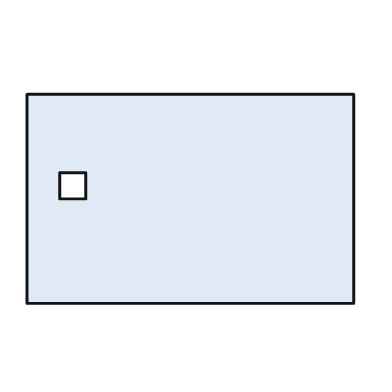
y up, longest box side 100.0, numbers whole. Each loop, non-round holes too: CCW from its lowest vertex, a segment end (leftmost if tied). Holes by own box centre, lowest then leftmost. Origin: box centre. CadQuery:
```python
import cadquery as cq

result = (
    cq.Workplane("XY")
    .moveTo(-50.0, -32.0)
    .lineTo(50.0, -32.0)
    .lineTo(50.0, 32.0)
    .lineTo(-50.0, 32.0)
    .close()
    .moveTo(-40.0, 0.0)
    .lineTo(-32.0, 0.0)
    .lineTo(-32.0, 8.0)
    .lineTo(-40.0, 8.0)
    .close()
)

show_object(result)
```